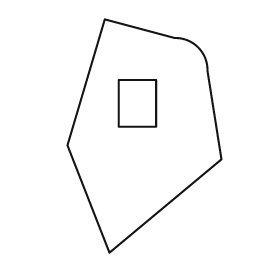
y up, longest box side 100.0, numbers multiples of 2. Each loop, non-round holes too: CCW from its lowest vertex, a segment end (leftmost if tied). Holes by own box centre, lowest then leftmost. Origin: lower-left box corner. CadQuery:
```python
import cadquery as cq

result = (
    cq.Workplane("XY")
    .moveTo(18.0, 0.0)
    .lineTo(66.0, 40.0)
    .lineTo(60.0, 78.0)
    .threePointArc((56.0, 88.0), (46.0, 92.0))
    .lineTo(16.0, 100.0)
    .lineTo(0.0, 46.0)
    .close()
    .moveTo(22.0, 54.0)
    .lineTo(38.0, 54.0)
    .lineTo(38.0, 74.0)
    .lineTo(22.0, 74.0)
    .close()
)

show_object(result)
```